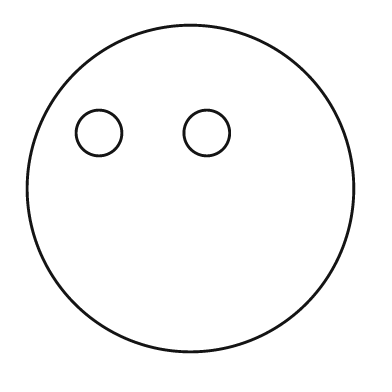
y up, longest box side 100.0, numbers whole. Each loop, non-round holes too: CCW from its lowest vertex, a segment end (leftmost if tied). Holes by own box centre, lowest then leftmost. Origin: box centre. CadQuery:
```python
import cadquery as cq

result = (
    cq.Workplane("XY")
    .moveTo(0.0, 0.0)
    .circle(50.0)
    .moveTo(-28.0, 17.0)
    .circle(7.0)
    .moveTo(5.0, 17.0)
    .circle(7.0)
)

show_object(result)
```